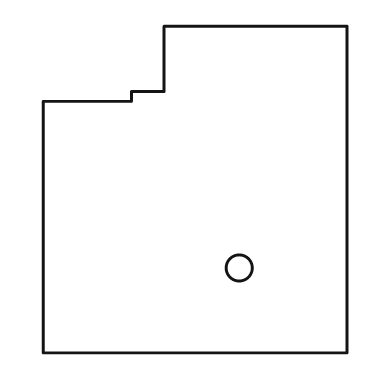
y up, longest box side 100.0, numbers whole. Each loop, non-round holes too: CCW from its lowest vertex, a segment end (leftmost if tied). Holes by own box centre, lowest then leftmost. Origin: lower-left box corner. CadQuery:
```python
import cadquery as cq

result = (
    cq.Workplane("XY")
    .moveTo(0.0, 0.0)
    .lineTo(93.0, 0.0)
    .lineTo(93.0, 100.0)
    .lineTo(37.0, 100.0)
    .lineTo(37.0, 80.0)
    .lineTo(27.0, 80.0)
    .lineTo(27.0, 77.0)
    .lineTo(0.0, 77.0)
    .close()
    .moveTo(60.0, 26.0)
    .circle(4.0)
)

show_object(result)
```